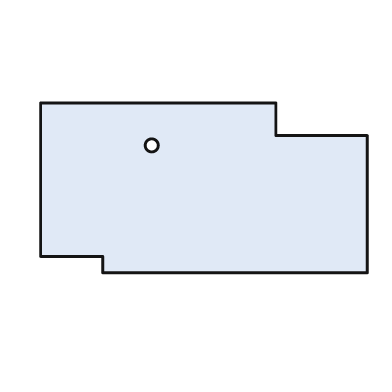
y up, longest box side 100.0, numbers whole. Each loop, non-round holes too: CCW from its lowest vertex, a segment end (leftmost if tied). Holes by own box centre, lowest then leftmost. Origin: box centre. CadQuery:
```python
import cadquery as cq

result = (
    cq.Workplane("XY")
    .moveTo(-31.0, -26.0)
    .lineTo(50.0, -26.0)
    .lineTo(50.0, 16.0)
    .lineTo(22.0, 16.0)
    .lineTo(22.0, 26.0)
    .lineTo(-50.0, 26.0)
    .lineTo(-50.0, -21.0)
    .lineTo(-31.0, -21.0)
    .close()
    .moveTo(-16.0, 13.0)
    .circle(2.0)
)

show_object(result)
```